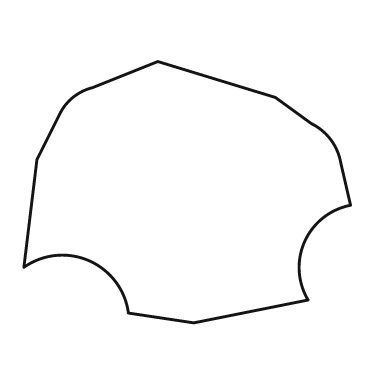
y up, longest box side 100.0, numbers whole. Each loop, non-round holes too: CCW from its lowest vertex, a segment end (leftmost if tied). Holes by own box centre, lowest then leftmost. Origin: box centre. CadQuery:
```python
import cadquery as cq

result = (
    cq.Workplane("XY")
    .moveTo(2.0, -40.0)
    .lineTo(37.0, -33.0)
    .threePointArc((36.0, -15.0), (50.0, -4.0))
    .lineTo(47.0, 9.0)
    .threePointArc((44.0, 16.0), (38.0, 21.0))
    .lineTo(27.0, 29.0)
    .lineTo(-9.0, 40.0)
    .lineTo(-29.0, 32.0)
    .threePointArc((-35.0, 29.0), (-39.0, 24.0))
    .lineTo(-46.0, 10.0)
    .lineTo(-50.0, -23.0)
    .threePointArc((-30.0, -21.0), (-18.0, -37.0))
    .close()
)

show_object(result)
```